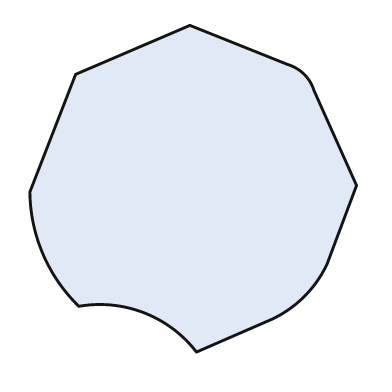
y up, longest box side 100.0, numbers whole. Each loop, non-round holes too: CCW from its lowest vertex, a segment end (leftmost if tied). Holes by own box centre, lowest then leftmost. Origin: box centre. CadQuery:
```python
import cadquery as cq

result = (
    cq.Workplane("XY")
    .moveTo(1.0, -50.0)
    .lineTo(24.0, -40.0)
    .threePointArc((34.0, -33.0), (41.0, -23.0))
    .lineTo(50.0, 1.0)
    .lineTo(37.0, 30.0)
    .threePointArc((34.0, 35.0), (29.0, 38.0))
    .lineTo(-1.0, 50.0)
    .lineTo(-36.0, 35.0)
    .lineTo(-50.0, -1.0)
    .threePointArc((-46.0, -20.0), (-35.0, -36.0))
    .threePointArc((-15.0, -38.0), (1.0, -50.0))
    .close()
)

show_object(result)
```